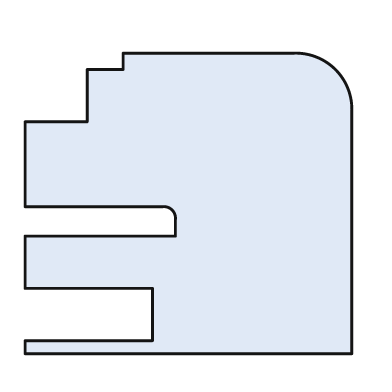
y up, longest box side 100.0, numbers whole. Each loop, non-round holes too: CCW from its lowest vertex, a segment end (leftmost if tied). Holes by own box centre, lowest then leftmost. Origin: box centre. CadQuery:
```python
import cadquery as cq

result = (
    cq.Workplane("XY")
    .moveTo(-50.0, -46.0)
    .lineTo(50.0, -46.0)
    .lineTo(50.0, 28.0)
    .threePointArc((45.0, 41.0), (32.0, 46.0))
    .lineTo(-20.0, 46.0)
    .lineTo(-20.0, 41.0)
    .lineTo(-31.0, 41.0)
    .lineTo(-31.0, 25.0)
    .lineTo(-50.0, 25.0)
    .lineTo(-50.0, -1.0)
    .lineTo(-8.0, -1.0)
    .threePointArc((-5.0, -2.0), (-4.0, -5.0))
    .lineTo(-4.0, -10.0)
    .lineTo(-50.0, -10.0)
    .lineTo(-50.0, -26.0)
    .lineTo(-11.0, -26.0)
    .lineTo(-11.0, -42.0)
    .lineTo(-50.0, -42.0)
    .close()
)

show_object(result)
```